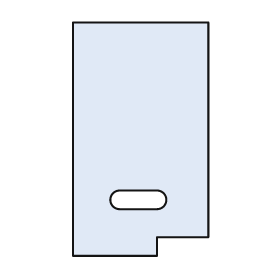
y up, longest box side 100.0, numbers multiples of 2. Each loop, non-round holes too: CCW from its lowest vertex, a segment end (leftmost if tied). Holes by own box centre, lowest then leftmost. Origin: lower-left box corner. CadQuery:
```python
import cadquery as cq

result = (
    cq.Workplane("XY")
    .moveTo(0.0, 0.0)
    .lineTo(36.0, 0.0)
    .lineTo(36.0, 8.0)
    .lineTo(58.0, 8.0)
    .lineTo(58.0, 100.0)
    .lineTo(0.0, 100.0)
    .close()
    .moveTo(20.0, 20.0)
    .lineTo(36.0, 20.0)
    .threePointArc((40.0, 24.0), (36.0, 28.0))
    .lineTo(20.0, 28.0)
    .threePointArc((16.0, 24.0), (20.0, 20.0))
    .close()
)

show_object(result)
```